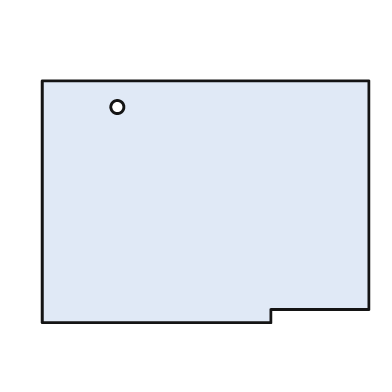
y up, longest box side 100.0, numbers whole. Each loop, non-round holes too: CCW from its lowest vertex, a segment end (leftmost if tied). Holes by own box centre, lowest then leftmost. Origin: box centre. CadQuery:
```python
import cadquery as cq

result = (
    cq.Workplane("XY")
    .moveTo(-50.0, -37.0)
    .lineTo(20.0, -37.0)
    .lineTo(20.0, -33.0)
    .lineTo(50.0, -33.0)
    .lineTo(50.0, 37.0)
    .lineTo(-50.0, 37.0)
    .close()
    .moveTo(-27.0, 29.0)
    .circle(2.0)
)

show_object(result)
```